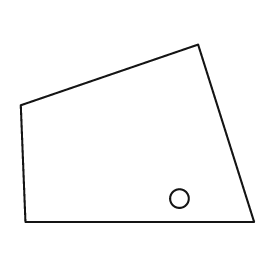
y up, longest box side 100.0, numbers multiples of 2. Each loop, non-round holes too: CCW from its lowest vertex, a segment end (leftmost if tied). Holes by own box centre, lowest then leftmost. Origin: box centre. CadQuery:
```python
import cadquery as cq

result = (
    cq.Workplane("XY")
    .moveTo(-48.0, -38.0)
    .lineTo(50.0, -38.0)
    .lineTo(26.0, 38.0)
    .lineTo(-50.0, 12.0)
    .close()
    .moveTo(18.0, -28.0)
    .circle(4.0)
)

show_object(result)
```